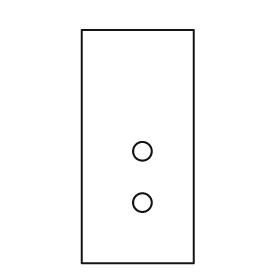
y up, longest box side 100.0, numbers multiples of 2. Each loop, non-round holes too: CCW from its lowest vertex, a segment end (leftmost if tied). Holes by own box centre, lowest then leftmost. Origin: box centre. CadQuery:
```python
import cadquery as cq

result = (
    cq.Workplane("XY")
    .moveTo(-24.0, -50.0)
    .lineTo(24.0, -50.0)
    .lineTo(24.0, 50.0)
    .lineTo(-24.0, 50.0)
    .close()
    .moveTo(2.0, -24.0)
    .circle(4.0)
    .moveTo(2.0, -2.0)
    .circle(4.0)
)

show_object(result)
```